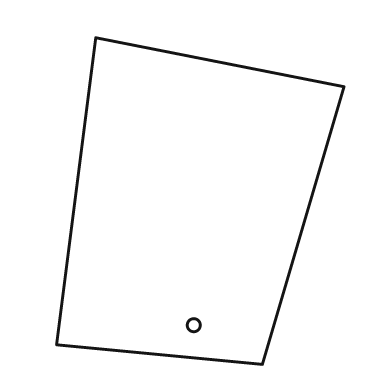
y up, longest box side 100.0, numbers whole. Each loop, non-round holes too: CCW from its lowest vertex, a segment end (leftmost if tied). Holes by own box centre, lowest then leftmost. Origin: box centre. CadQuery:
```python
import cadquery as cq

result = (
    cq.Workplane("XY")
    .moveTo(19.0, -50.0)
    .lineTo(44.0, 35.0)
    .lineTo(-32.0, 50.0)
    .lineTo(-44.0, -44.0)
    .close()
    .moveTo(-2.0, -38.0)
    .circle(2.0)
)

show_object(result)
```